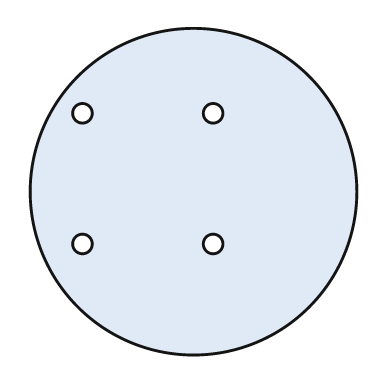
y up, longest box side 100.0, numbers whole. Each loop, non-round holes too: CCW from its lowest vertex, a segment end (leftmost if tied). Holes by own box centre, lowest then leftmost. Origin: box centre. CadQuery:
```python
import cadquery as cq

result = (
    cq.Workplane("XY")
    .moveTo(0.0, 0.0)
    .circle(50.0)
    .moveTo(-34.0, -16.0)
    .circle(3.0)
    .moveTo(6.0, -16.0)
    .circle(3.0)
    .moveTo(-34.0, 24.0)
    .circle(3.0)
    .moveTo(6.0, 24.0)
    .circle(3.0)
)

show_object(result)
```